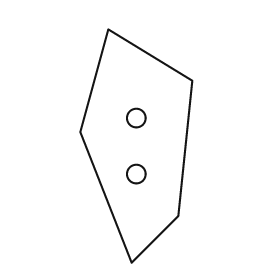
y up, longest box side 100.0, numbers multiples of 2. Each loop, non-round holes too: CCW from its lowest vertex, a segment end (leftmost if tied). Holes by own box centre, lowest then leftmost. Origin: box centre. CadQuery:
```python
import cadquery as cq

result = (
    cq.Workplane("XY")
    .moveTo(-2.0, -50.0)
    .lineTo(18.0, -30.0)
    .lineTo(24.0, 28.0)
    .lineTo(-12.0, 50.0)
    .lineTo(-24.0, 6.0)
    .close()
    .moveTo(0.0, -12.0)
    .circle(4.0)
    .moveTo(0.0, 12.0)
    .circle(4.0)
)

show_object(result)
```